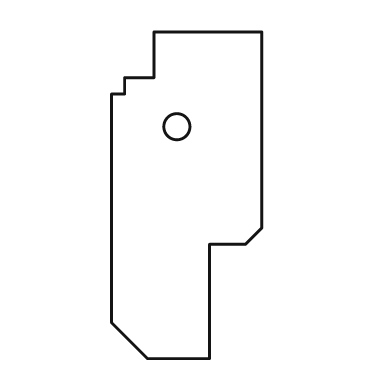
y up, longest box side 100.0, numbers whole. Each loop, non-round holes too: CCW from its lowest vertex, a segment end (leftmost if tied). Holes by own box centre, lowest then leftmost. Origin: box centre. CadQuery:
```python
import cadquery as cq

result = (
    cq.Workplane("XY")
    .moveTo(-12.0, -50.0)
    .lineTo(7.0, -50.0)
    .lineTo(7.0, -15.0)
    .lineTo(18.0, -15.0)
    .lineTo(23.0, -10.0)
    .lineTo(23.0, 50.0)
    .lineTo(-10.0, 50.0)
    .lineTo(-10.0, 36.0)
    .lineTo(-19.0, 36.0)
    .lineTo(-19.0, 31.0)
    .lineTo(-23.0, 31.0)
    .lineTo(-23.0, -39.0)
    .close()
    .moveTo(-3.0, 21.0)
    .circle(4.0)
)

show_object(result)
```